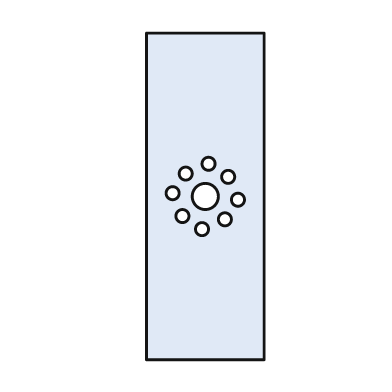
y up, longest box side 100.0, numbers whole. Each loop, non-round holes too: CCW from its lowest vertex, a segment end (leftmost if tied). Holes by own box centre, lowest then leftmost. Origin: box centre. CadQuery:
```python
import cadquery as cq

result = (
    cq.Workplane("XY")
    .moveTo(-18.0, -50.0)
    .lineTo(18.0, -50.0)
    .lineTo(18.0, 50.0)
    .lineTo(-18.0, 50.0)
    .close()
    .moveTo(-1.0, -10.0)
    .circle(2.0)
    .moveTo(6.0, -7.0)
    .circle(2.0)
    .moveTo(-7.0, -6.0)
    .circle(2.0)
    .moveTo(10.0, -1.0)
    .circle(2.0)
    .moveTo(0.0, 0.0)
    .circle(4.0)
    .moveTo(-10.0, 1.0)
    .circle(2.0)
    .moveTo(7.0, 6.0)
    .circle(2.0)
    .moveTo(-6.0, 7.0)
    .circle(2.0)
    .moveTo(1.0, 10.0)
    .circle(2.0)
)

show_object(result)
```